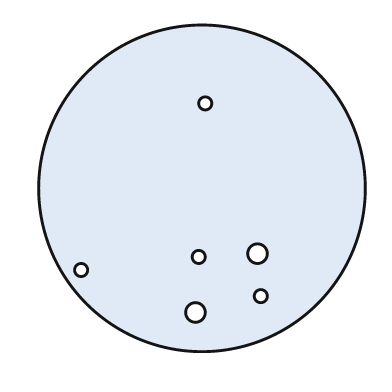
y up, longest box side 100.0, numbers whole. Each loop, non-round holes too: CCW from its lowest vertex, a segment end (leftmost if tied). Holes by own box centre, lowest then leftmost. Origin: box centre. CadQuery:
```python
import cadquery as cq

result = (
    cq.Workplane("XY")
    .moveTo(0.0, 0.0)
    .circle(50.0)
    .moveTo(-2.0, -38.0)
    .circle(3.0)
    .moveTo(18.0, -33.0)
    .circle(2.0)
    .moveTo(-37.0, -25.0)
    .circle(2.0)
    .moveTo(-1.0, -21.0)
    .circle(2.0)
    .moveTo(17.0, -20.0)
    .circle(3.0)
    .moveTo(1.0, 26.0)
    .circle(2.0)
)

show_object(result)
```